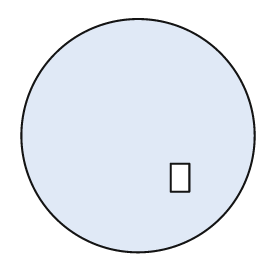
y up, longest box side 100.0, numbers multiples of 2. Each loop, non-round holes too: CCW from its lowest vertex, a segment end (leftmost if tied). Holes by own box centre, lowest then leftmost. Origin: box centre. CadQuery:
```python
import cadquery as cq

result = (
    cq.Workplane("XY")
    .moveTo(0.0, 0.0)
    .circle(50.0)
    .moveTo(14.0, -24.0)
    .lineTo(22.0, -24.0)
    .lineTo(22.0, -12.0)
    .lineTo(14.0, -12.0)
    .close()
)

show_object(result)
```